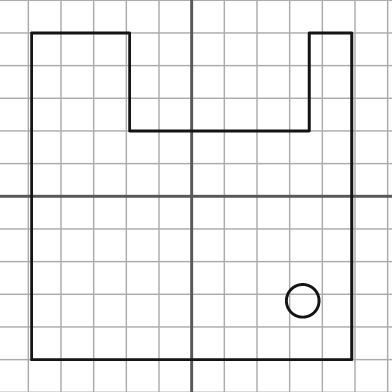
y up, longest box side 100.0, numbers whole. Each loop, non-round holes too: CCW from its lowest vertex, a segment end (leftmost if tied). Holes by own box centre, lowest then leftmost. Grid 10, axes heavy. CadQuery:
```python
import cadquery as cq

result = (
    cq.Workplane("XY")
    .moveTo(-49.0, -50.0)
    .lineTo(49.0, -50.0)
    .lineTo(49.0, 50.0)
    .lineTo(36.0, 50.0)
    .lineTo(36.0, 20.0)
    .lineTo(-19.0, 20.0)
    .lineTo(-19.0, 50.0)
    .lineTo(-49.0, 50.0)
    .close()
    .moveTo(34.0, -32.0)
    .circle(5.0)
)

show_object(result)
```